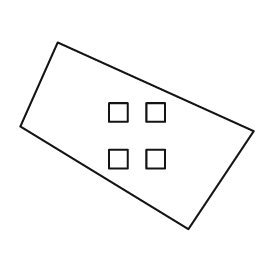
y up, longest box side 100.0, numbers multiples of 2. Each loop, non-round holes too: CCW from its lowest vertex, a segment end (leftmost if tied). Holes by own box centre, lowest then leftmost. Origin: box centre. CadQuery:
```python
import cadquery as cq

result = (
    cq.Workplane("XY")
    .moveTo(22.0, -40.0)
    .lineTo(50.0, 2.0)
    .lineTo(-34.0, 40.0)
    .lineTo(-50.0, 4.0)
    .close()
    .moveTo(-12.0, -14.0)
    .lineTo(-4.0, -14.0)
    .lineTo(-4.0, -6.0)
    .lineTo(-12.0, -6.0)
    .close()
    .moveTo(4.0, -14.0)
    .lineTo(12.0, -14.0)
    .lineTo(12.0, -6.0)
    .lineTo(4.0, -6.0)
    .close()
    .moveTo(-12.0, 6.0)
    .lineTo(-4.0, 6.0)
    .lineTo(-4.0, 14.0)
    .lineTo(-12.0, 14.0)
    .close()
    .moveTo(4.0, 6.0)
    .lineTo(12.0, 6.0)
    .lineTo(12.0, 14.0)
    .lineTo(4.0, 14.0)
    .close()
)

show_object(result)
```